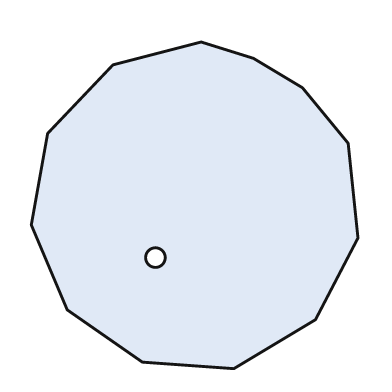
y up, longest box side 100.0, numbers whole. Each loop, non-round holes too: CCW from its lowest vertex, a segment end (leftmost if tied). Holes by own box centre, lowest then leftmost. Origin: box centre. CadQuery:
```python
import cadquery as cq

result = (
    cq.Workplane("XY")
    .moveTo(12.0, -50.0)
    .lineTo(37.0, -35.0)
    .lineTo(50.0, -10.0)
    .lineTo(47.0, 19.0)
    .lineTo(33.0, 36.0)
    .lineTo(18.0, 45.0)
    .lineTo(2.0, 50.0)
    .lineTo(-25.0, 43.0)
    .lineTo(-45.0, 22.0)
    .lineTo(-50.0, -6.0)
    .lineTo(-39.0, -32.0)
    .lineTo(-16.0, -48.0)
    .close()
    .moveTo(-12.0, -16.0)
    .circle(3.0)
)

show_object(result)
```